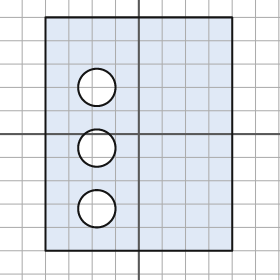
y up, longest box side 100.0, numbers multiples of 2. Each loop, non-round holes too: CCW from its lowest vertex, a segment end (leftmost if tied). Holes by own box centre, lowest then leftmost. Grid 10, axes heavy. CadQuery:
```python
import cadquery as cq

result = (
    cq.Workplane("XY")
    .moveTo(-40.0, -50.0)
    .lineTo(40.0, -50.0)
    .lineTo(40.0, 50.0)
    .lineTo(-40.0, 50.0)
    .close()
    .moveTo(-18.0, -32.0)
    .circle(8.0)
    .moveTo(-18.0, -6.0)
    .circle(8.0)
    .moveTo(-18.0, 20.0)
    .circle(8.0)
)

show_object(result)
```